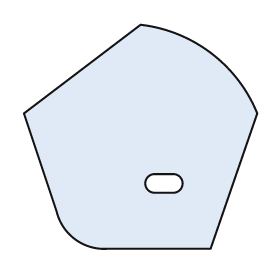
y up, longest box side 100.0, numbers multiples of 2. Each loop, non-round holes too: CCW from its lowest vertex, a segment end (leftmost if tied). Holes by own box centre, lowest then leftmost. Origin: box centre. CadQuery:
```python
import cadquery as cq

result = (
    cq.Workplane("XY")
    .moveTo(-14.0, -48.0)
    .lineTo(30.0, -48.0)
    .lineTo(50.0, 10.0)
    .threePointArc((30.0, 36.0), (0.0, 48.0))
    .lineTo(-50.0, 10.0)
    .lineTo(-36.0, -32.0)
    .threePointArc((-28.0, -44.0), (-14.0, -48.0))
    .close()
    .moveTo(6.0, -24.0)
    .lineTo(14.0, -24.0)
    .threePointArc((18.0, -20.0), (14.0, -16.0))
    .lineTo(6.0, -16.0)
    .threePointArc((2.0, -20.0), (6.0, -24.0))
    .close()
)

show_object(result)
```